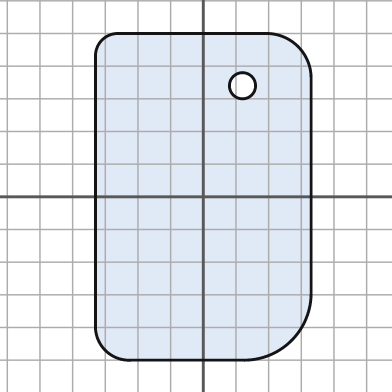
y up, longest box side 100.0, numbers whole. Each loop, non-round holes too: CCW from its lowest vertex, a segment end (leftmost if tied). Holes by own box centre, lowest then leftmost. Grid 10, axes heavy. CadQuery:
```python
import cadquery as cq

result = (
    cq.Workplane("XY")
    .moveTo(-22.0, -50.0)
    .lineTo(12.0, -50.0)
    .threePointArc((27.0, -44.0), (33.0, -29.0))
    .lineTo(33.0, 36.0)
    .threePointArc((29.0, 46.0), (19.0, 50.0))
    .lineTo(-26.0, 50.0)
    .threePointArc((-31.0, 48.0), (-33.0, 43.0))
    .lineTo(-33.0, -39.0)
    .threePointArc((-30.0, -47.0), (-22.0, -50.0))
    .close()
    .moveTo(12.0, 34.0)
    .circle(4.0)
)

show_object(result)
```